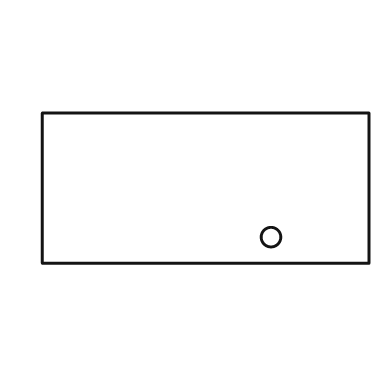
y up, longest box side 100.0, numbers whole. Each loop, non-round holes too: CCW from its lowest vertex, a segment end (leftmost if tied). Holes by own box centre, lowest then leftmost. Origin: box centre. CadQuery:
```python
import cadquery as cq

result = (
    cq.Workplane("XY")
    .moveTo(-50.0, -23.0)
    .lineTo(50.0, -23.0)
    .lineTo(50.0, 23.0)
    .lineTo(-50.0, 23.0)
    .close()
    .moveTo(20.0, -15.0)
    .circle(3.0)
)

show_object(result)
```